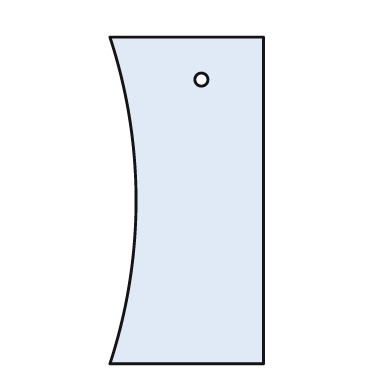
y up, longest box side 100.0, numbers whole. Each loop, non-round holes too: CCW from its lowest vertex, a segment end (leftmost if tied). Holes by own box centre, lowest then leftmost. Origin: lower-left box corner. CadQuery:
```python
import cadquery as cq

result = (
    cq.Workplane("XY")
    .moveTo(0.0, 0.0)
    .lineTo(47.0, 0.0)
    .lineTo(47.0, 100.0)
    .lineTo(0.0, 100.0)
    .threePointArc((8.0, 50.0), (0.0, 0.0))
    .close()
    .moveTo(28.0, 87.0)
    .circle(2.0)
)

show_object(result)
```